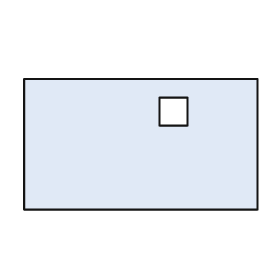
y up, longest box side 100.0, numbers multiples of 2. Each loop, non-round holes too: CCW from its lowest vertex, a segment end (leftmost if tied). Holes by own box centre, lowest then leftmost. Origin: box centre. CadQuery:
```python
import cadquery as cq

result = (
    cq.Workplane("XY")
    .moveTo(-50.0, -28.0)
    .lineTo(50.0, -28.0)
    .lineTo(50.0, 28.0)
    .lineTo(-50.0, 28.0)
    .close()
    .moveTo(8.0, 8.0)
    .lineTo(20.0, 8.0)
    .lineTo(20.0, 20.0)
    .lineTo(8.0, 20.0)
    .close()
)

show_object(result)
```